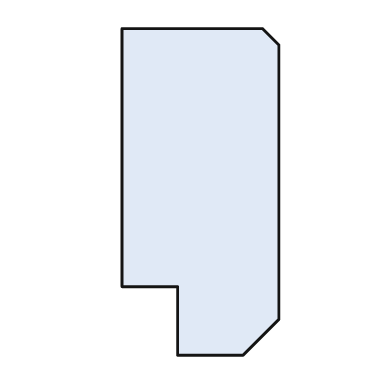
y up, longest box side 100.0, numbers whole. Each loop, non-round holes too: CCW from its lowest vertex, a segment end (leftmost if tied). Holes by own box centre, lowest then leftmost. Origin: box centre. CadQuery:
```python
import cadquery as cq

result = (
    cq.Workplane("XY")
    .moveTo(-7.0, -50.0)
    .lineTo(13.0, -50.0)
    .lineTo(24.0, -39.0)
    .lineTo(24.0, 45.0)
    .lineTo(19.0, 50.0)
    .lineTo(-24.0, 50.0)
    .lineTo(-24.0, -29.0)
    .lineTo(-7.0, -29.0)
    .close()
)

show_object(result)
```